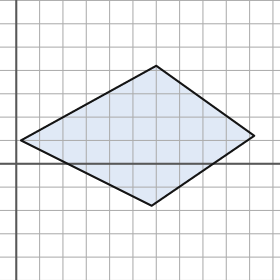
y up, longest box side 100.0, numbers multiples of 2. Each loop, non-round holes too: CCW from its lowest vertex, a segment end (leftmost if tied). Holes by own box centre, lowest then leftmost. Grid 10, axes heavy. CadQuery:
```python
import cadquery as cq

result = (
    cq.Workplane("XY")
    .moveTo(58.0, -18.0)
    .lineTo(102.0, 12.0)
    .lineTo(60.0, 42.0)
    .lineTo(2.0, 10.0)
    .close()
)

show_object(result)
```